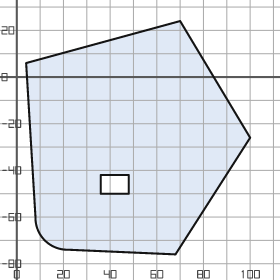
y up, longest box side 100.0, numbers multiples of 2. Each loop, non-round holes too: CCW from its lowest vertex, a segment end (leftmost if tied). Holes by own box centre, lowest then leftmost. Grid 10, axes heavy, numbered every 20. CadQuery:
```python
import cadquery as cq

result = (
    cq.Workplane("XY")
    .moveTo(68.0, -76.0)
    .lineTo(100.0, -26.0)
    .lineTo(70.0, 24.0)
    .lineTo(4.0, 6.0)
    .lineTo(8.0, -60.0)
    .threePointArc((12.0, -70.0), (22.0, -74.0))
    .close()
    .moveTo(36.0, -50.0)
    .lineTo(48.0, -50.0)
    .lineTo(48.0, -42.0)
    .lineTo(36.0, -42.0)
    .close()
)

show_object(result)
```